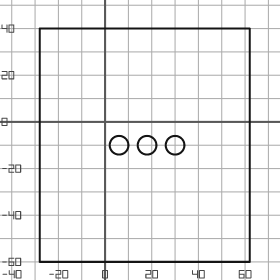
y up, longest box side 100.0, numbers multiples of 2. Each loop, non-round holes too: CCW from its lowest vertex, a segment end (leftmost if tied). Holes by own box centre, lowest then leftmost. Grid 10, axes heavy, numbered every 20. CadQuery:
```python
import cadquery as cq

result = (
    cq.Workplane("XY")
    .moveTo(-28.0, -60.0)
    .lineTo(62.0, -60.0)
    .lineTo(62.0, 40.0)
    .lineTo(-28.0, 40.0)
    .close()
    .moveTo(6.0, -10.0)
    .circle(4.0)
    .moveTo(18.0, -10.0)
    .circle(4.0)
    .moveTo(30.0, -10.0)
    .circle(4.0)
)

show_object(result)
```